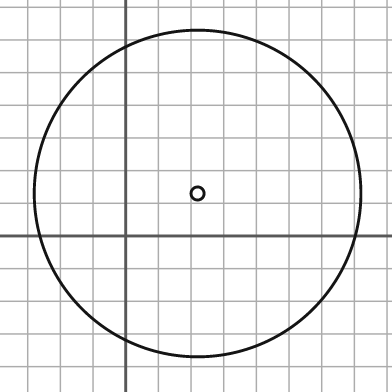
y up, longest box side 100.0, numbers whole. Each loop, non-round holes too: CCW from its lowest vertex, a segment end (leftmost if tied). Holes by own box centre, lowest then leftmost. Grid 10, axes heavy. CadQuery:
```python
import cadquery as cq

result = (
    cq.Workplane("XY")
    .moveTo(22.0, 13.0)
    .circle(50.0)
    .moveTo(22.0, 13.0)
    .circle(2.0)
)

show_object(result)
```